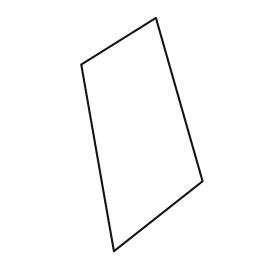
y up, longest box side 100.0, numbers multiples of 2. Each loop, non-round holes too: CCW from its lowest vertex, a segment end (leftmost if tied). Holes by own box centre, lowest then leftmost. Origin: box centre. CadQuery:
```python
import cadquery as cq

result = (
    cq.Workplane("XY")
    .moveTo(-12.0, -50.0)
    .lineTo(26.0, -20.0)
    .lineTo(6.0, 50.0)
    .lineTo(-26.0, 30.0)
    .close()
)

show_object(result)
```